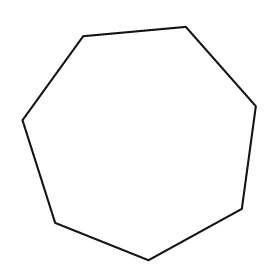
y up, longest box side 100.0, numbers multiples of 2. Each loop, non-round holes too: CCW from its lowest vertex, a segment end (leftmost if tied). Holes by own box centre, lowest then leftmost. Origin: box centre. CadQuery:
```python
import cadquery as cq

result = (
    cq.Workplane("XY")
    .moveTo(4.0, -50.0)
    .lineTo(44.0, -28.0)
    .lineTo(50.0, 16.0)
    .lineTo(20.0, 50.0)
    .lineTo(-24.0, 46.0)
    .lineTo(-50.0, 10.0)
    .lineTo(-36.0, -34.0)
    .close()
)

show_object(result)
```